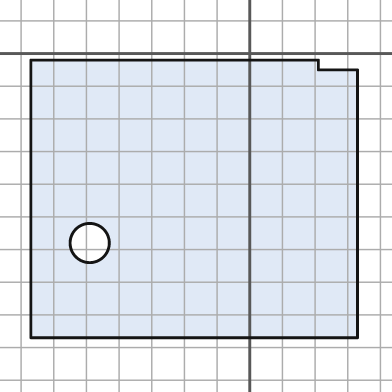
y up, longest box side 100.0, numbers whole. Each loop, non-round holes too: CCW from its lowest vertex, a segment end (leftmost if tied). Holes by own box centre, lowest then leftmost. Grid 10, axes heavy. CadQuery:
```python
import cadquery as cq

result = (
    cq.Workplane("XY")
    .moveTo(-67.0, -87.0)
    .lineTo(33.0, -87.0)
    .lineTo(33.0, -5.0)
    .lineTo(21.0, -5.0)
    .lineTo(21.0, -2.0)
    .lineTo(-67.0, -2.0)
    .close()
    .moveTo(-49.0, -58.0)
    .circle(6.0)
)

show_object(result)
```